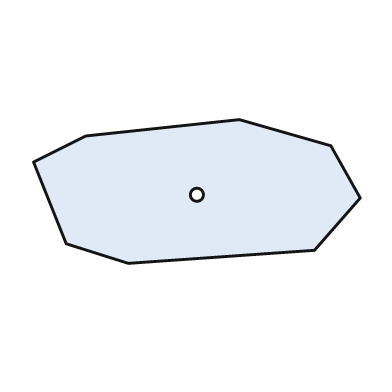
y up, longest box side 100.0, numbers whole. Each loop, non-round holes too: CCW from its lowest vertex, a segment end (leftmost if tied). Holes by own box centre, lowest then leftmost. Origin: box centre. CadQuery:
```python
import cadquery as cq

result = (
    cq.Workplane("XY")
    .moveTo(-21.0, -22.0)
    .lineTo(36.0, -18.0)
    .lineTo(50.0, -2.0)
    .lineTo(41.0, 14.0)
    .lineTo(13.0, 22.0)
    .lineTo(-34.0, 17.0)
    .lineTo(-50.0, 9.0)
    .lineTo(-40.0, -16.0)
    .close()
    .moveTo(0.0, -1.0)
    .circle(2.0)
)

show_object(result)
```